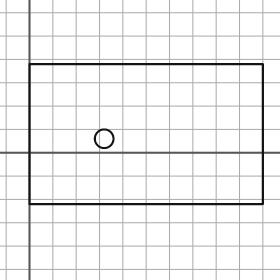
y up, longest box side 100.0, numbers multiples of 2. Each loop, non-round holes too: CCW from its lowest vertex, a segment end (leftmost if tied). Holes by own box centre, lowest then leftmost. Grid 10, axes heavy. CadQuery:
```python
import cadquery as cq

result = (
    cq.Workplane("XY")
    .moveTo(0.0, -22.0)
    .lineTo(100.0, -22.0)
    .lineTo(100.0, 38.0)
    .lineTo(0.0, 38.0)
    .close()
    .moveTo(32.0, 6.0)
    .circle(4.0)
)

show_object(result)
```